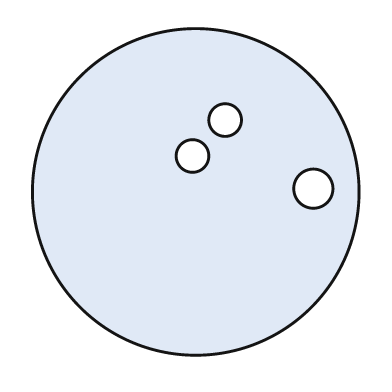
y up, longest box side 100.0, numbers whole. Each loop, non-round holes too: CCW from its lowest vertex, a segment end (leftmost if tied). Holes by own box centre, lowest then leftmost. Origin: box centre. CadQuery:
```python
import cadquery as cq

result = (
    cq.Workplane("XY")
    .moveTo(0.0, 0.0)
    .circle(50.0)
    .moveTo(36.0, 1.0)
    .circle(6.0)
    .moveTo(-1.0, 11.0)
    .circle(5.0)
    .moveTo(9.0, 22.0)
    .circle(5.0)
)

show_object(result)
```